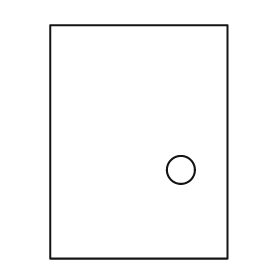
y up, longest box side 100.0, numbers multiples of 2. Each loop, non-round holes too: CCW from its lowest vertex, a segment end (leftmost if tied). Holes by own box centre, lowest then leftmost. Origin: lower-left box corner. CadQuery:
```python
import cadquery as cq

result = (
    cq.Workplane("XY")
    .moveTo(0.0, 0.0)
    .lineTo(76.0, 0.0)
    .lineTo(76.0, 100.0)
    .lineTo(0.0, 100.0)
    .close()
    .moveTo(56.0, 38.0)
    .circle(6.0)
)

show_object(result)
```